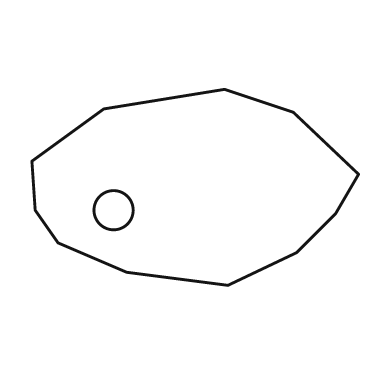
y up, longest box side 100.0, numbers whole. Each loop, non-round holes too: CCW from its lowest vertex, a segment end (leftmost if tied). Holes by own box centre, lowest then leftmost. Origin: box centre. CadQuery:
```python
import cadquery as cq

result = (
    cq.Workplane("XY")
    .moveTo(10.0, -30.0)
    .lineTo(31.0, -20.0)
    .lineTo(43.0, -8.0)
    .lineTo(50.0, 4.0)
    .lineTo(30.0, 23.0)
    .lineTo(9.0, 30.0)
    .lineTo(-28.0, 24.0)
    .lineTo(-50.0, 8.0)
    .lineTo(-49.0, -7.0)
    .lineTo(-42.0, -17.0)
    .lineTo(-21.0, -26.0)
    .close()
    .moveTo(-25.0, -7.0)
    .circle(6.0)
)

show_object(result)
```